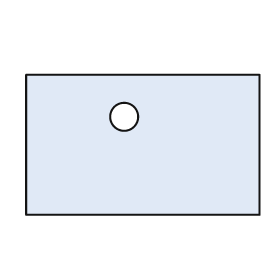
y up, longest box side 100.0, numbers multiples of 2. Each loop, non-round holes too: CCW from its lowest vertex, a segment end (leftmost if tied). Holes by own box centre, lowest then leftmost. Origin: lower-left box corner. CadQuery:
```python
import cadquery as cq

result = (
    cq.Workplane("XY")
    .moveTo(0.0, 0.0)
    .lineTo(100.0, 0.0)
    .lineTo(100.0, 60.0)
    .lineTo(0.0, 60.0)
    .close()
    .moveTo(42.0, 42.0)
    .circle(6.0)
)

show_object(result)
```